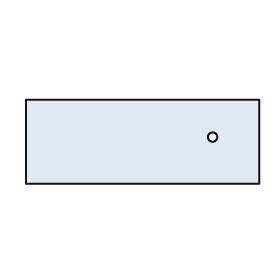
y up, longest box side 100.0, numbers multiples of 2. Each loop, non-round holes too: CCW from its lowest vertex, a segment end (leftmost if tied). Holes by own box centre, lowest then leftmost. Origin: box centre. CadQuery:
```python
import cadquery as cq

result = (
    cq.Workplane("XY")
    .moveTo(-50.0, -18.0)
    .lineTo(50.0, -18.0)
    .lineTo(50.0, 18.0)
    .lineTo(-50.0, 18.0)
    .close()
    .moveTo(30.0, 2.0)
    .circle(2.0)
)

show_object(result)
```